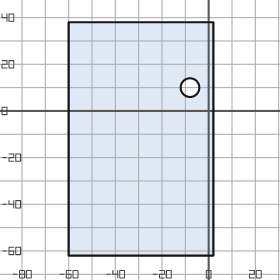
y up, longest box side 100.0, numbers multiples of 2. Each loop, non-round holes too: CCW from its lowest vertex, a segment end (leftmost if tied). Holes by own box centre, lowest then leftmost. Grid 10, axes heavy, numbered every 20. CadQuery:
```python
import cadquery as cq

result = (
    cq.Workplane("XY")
    .moveTo(-60.0, -62.0)
    .lineTo(2.0, -62.0)
    .lineTo(2.0, 38.0)
    .lineTo(-60.0, 38.0)
    .close()
    .moveTo(-8.0, 10.0)
    .circle(4.0)
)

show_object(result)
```